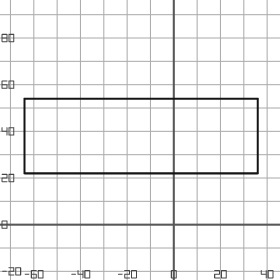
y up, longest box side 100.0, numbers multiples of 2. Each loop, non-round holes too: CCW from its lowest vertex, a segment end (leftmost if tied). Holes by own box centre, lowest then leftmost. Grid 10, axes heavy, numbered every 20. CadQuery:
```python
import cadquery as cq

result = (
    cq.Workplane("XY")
    .moveTo(-64.0, 22.0)
    .lineTo(36.0, 22.0)
    .lineTo(36.0, 54.0)
    .lineTo(-64.0, 54.0)
    .close()
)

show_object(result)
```